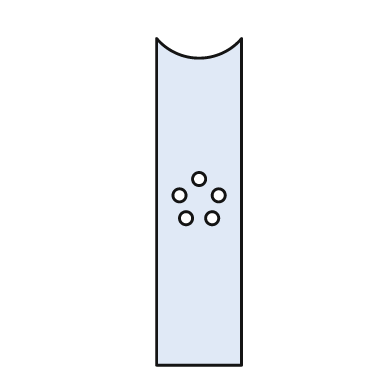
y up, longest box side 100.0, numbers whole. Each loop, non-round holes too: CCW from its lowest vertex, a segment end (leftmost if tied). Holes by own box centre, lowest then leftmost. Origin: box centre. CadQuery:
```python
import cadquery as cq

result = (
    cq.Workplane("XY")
    .moveTo(-13.0, -50.0)
    .lineTo(13.0, -50.0)
    .lineTo(13.0, 50.0)
    .threePointArc((0.0, 44.0), (-13.0, 50.0))
    .close()
    .moveTo(-4.0, -5.0)
    .circle(2.0)
    .moveTo(4.0, -5.0)
    .circle(2.0)
    .moveTo(-6.0, 2.0)
    .circle(2.0)
    .moveTo(6.0, 2.0)
    .circle(2.0)
    .moveTo(0.0, 7.0)
    .circle(2.0)
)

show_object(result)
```